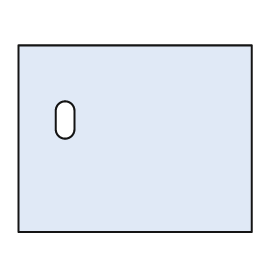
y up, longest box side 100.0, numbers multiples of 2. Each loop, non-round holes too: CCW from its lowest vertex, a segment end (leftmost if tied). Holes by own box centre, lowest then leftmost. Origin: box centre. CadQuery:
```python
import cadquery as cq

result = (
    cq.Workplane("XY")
    .moveTo(-50.0, -40.0)
    .lineTo(50.0, -40.0)
    .lineTo(50.0, 40.0)
    .lineTo(-50.0, 40.0)
    .close()
    .moveTo(-34.0, 4.0)
    .threePointArc((-30.0, 0.0), (-26.0, 4.0))
    .lineTo(-26.0, 12.0)
    .threePointArc((-30.0, 16.0), (-34.0, 12.0))
    .close()
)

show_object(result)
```